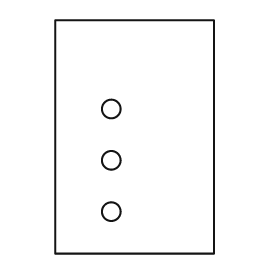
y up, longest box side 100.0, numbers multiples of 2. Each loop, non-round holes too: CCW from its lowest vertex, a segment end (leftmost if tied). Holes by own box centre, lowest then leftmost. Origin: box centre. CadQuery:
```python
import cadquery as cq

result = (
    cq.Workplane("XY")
    .moveTo(-34.0, -50.0)
    .lineTo(34.0, -50.0)
    .lineTo(34.0, 50.0)
    .lineTo(-34.0, 50.0)
    .close()
    .moveTo(-10.0, -32.0)
    .circle(4.0)
    .moveTo(-10.0, -10.0)
    .circle(4.0)
    .moveTo(-10.0, 12.0)
    .circle(4.0)
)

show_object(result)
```